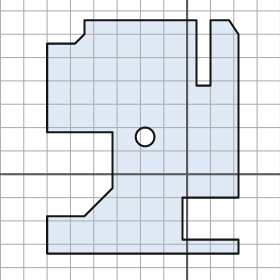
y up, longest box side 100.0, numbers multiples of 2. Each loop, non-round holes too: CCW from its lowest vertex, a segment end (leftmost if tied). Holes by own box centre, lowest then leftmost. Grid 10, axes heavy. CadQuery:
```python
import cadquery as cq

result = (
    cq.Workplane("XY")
    .moveTo(-60.0, -34.0)
    .lineTo(22.0, -34.0)
    .lineTo(22.0, -28.0)
    .lineTo(-2.0, -28.0)
    .lineTo(-2.0, -10.0)
    .lineTo(22.0, -10.0)
    .lineTo(22.0, 60.0)
    .lineTo(18.0, 66.0)
    .lineTo(10.0, 66.0)
    .lineTo(10.0, 38.0)
    .lineTo(4.0, 38.0)
    .lineTo(4.0, 66.0)
    .lineTo(-44.0, 66.0)
    .lineTo(-44.0, 60.0)
    .lineTo(-48.0, 56.0)
    .lineTo(-60.0, 56.0)
    .lineTo(-60.0, 18.0)
    .lineTo(-32.0, 18.0)
    .lineTo(-32.0, -6.0)
    .lineTo(-44.0, -18.0)
    .lineTo(-60.0, -18.0)
    .close()
    .moveTo(-18.0, 16.0)
    .circle(4.0)
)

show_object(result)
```